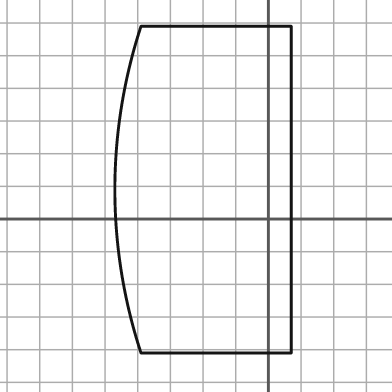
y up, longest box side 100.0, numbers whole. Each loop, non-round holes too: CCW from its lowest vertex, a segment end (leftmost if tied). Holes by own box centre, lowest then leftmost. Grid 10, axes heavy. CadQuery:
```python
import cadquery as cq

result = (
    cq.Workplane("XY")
    .moveTo(-39.0, -41.0)
    .lineTo(7.0, -41.0)
    .lineTo(7.0, 59.0)
    .lineTo(-39.0, 59.0)
    .threePointArc((-47.0, 9.0), (-39.0, -41.0))
    .close()
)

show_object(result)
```